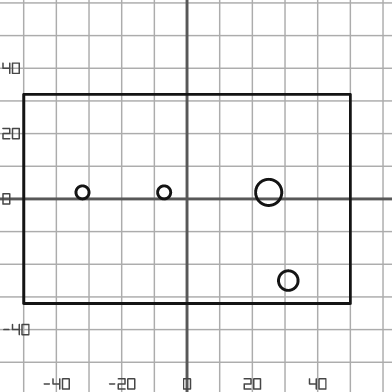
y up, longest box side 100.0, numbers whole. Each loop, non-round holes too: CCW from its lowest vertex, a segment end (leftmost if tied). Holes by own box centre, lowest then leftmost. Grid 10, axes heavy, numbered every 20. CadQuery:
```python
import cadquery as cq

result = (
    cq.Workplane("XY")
    .moveTo(-50.0, -32.0)
    .lineTo(50.0, -32.0)
    .lineTo(50.0, 32.0)
    .lineTo(-50.0, 32.0)
    .close()
    .moveTo(31.0, -25.0)
    .circle(3.0)
    .moveTo(-32.0, 2.0)
    .circle(2.0)
    .moveTo(-7.0, 2.0)
    .circle(2.0)
    .moveTo(25.0, 2.0)
    .circle(4.0)
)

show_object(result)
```